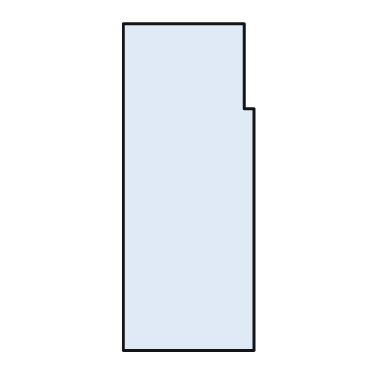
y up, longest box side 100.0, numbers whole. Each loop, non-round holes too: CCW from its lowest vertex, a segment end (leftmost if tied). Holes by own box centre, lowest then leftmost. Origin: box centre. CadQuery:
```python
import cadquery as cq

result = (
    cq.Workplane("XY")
    .moveTo(-20.0, -50.0)
    .lineTo(20.0, -50.0)
    .lineTo(20.0, 24.0)
    .lineTo(17.0, 24.0)
    .lineTo(17.0, 50.0)
    .lineTo(-20.0, 50.0)
    .close()
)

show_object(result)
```